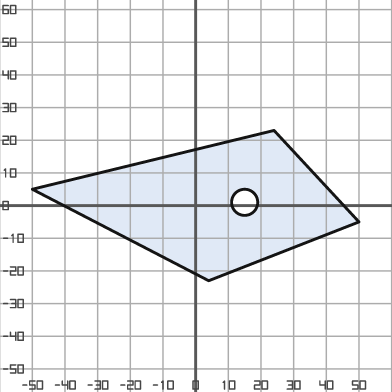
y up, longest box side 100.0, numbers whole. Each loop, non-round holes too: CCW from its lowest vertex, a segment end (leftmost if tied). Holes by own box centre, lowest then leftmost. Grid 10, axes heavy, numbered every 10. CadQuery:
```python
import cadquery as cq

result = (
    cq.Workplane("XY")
    .moveTo(4.0, -23.0)
    .lineTo(50.0, -5.0)
    .lineTo(24.0, 23.0)
    .lineTo(-50.0, 5.0)
    .close()
    .moveTo(15.0, 1.0)
    .circle(4.0)
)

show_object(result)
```